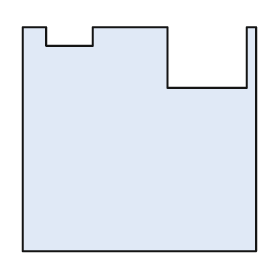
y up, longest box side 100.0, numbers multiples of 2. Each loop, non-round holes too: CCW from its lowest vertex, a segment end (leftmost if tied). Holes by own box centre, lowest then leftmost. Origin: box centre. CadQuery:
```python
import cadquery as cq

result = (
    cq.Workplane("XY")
    .moveTo(-50.0, -48.0)
    .lineTo(50.0, -48.0)
    .lineTo(50.0, 48.0)
    .lineTo(46.0, 48.0)
    .lineTo(46.0, 22.0)
    .lineTo(12.0, 22.0)
    .lineTo(12.0, 48.0)
    .lineTo(-20.0, 48.0)
    .lineTo(-20.0, 40.0)
    .lineTo(-40.0, 40.0)
    .lineTo(-40.0, 48.0)
    .lineTo(-50.0, 48.0)
    .close()
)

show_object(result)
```